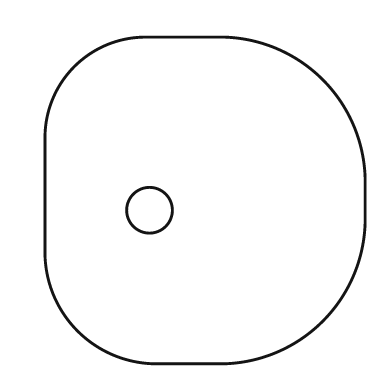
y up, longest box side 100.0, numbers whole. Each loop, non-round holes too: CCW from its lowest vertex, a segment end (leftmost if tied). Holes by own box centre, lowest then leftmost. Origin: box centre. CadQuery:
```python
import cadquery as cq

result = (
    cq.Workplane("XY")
    .moveTo(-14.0, -50.0)
    .lineTo(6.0, -50.0)
    .threePointArc((36.0, -37.0), (49.0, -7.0))
    .lineTo(49.0, 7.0)
    .threePointArc((36.0, 37.0), (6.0, 50.0))
    .lineTo(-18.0, 50.0)
    .threePointArc((-40.0, 41.0), (-49.0, 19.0))
    .lineTo(-49.0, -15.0)
    .threePointArc((-39.0, -40.0), (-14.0, -50.0))
    .close()
    .moveTo(-17.0, -3.0)
    .circle(7.0)
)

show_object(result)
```